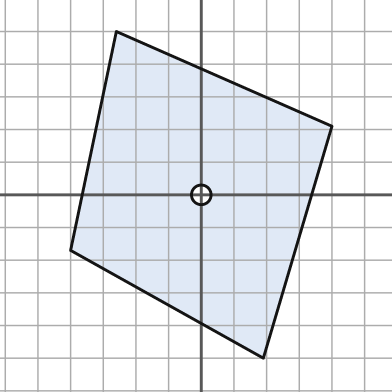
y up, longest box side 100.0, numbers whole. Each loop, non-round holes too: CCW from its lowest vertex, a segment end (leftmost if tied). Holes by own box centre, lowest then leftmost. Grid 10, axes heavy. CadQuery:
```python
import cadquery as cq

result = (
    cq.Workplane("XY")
    .moveTo(19.0, -50.0)
    .lineTo(40.0, 21.0)
    .lineTo(-26.0, 50.0)
    .lineTo(-40.0, -17.0)
    .close()
    .moveTo(0.0, 0.0)
    .circle(3.0)
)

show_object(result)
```